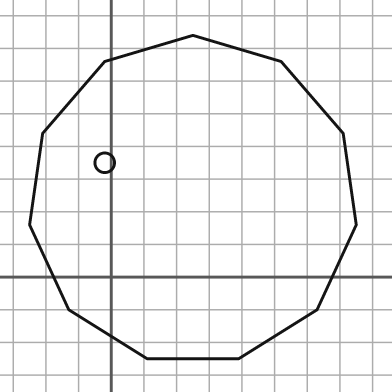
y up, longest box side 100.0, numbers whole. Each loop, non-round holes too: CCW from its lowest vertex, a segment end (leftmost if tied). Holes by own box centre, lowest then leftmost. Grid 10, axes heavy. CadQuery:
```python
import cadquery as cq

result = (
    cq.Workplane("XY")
    .moveTo(11.0, -25.0)
    .lineTo(39.0, -25.0)
    .lineTo(63.0, -10.0)
    .lineTo(75.0, 16.0)
    .lineTo(71.0, 44.0)
    .lineTo(52.0, 66.0)
    .lineTo(25.0, 74.0)
    .lineTo(-2.0, 66.0)
    .lineTo(-21.0, 44.0)
    .lineTo(-25.0, 16.0)
    .lineTo(-13.0, -10.0)
    .close()
    .moveTo(-2.0, 35.0)
    .circle(3.0)
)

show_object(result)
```